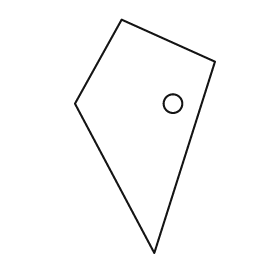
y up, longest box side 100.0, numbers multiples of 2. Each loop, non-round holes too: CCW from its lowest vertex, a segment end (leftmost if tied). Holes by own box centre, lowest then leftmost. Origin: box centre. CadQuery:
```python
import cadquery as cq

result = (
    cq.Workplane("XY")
    .moveTo(4.0, -50.0)
    .lineTo(30.0, 32.0)
    .lineTo(-10.0, 50.0)
    .lineTo(-30.0, 14.0)
    .close()
    .moveTo(12.0, 14.0)
    .circle(4.0)
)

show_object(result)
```